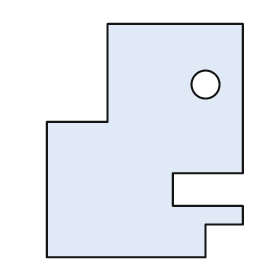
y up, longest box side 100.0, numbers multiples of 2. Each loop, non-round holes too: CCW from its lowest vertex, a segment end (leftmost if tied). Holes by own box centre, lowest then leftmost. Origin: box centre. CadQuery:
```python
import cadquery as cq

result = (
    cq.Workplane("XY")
    .moveTo(-42.0, -50.0)
    .lineTo(26.0, -50.0)
    .lineTo(26.0, -36.0)
    .lineTo(42.0, -36.0)
    .lineTo(42.0, -28.0)
    .lineTo(12.0, -28.0)
    .lineTo(12.0, -14.0)
    .lineTo(42.0, -14.0)
    .lineTo(42.0, 50.0)
    .lineTo(-16.0, 50.0)
    .lineTo(-16.0, 8.0)
    .lineTo(-42.0, 8.0)
    .close()
    .moveTo(26.0, 24.0)
    .circle(6.0)
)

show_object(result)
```